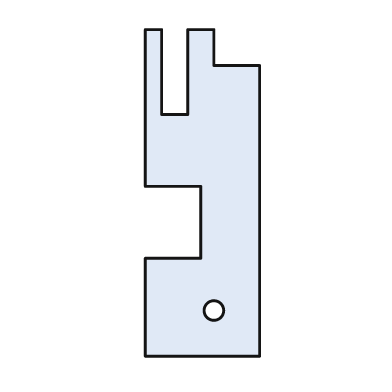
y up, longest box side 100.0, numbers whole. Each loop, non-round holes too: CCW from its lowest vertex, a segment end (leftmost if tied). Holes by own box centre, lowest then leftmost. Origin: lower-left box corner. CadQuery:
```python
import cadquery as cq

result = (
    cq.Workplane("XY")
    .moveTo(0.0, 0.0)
    .lineTo(35.0, 0.0)
    .lineTo(35.0, 89.0)
    .lineTo(21.0, 89.0)
    .lineTo(21.0, 100.0)
    .lineTo(13.0, 100.0)
    .lineTo(13.0, 74.0)
    .lineTo(5.0, 74.0)
    .lineTo(5.0, 100.0)
    .lineTo(0.0, 100.0)
    .lineTo(0.0, 52.0)
    .lineTo(17.0, 52.0)
    .lineTo(17.0, 30.0)
    .lineTo(0.0, 30.0)
    .close()
    .moveTo(21.0, 14.0)
    .circle(3.0)
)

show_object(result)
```